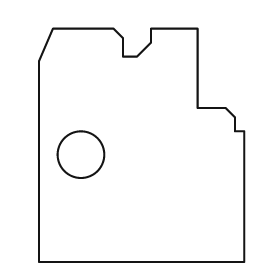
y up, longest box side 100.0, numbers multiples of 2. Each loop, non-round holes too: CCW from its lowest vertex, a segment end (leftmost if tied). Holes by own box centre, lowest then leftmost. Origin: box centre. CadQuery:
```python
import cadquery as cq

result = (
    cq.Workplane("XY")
    .moveTo(-44.0, -50.0)
    .lineTo(44.0, -50.0)
    .lineTo(44.0, 6.0)
    .lineTo(40.0, 6.0)
    .lineTo(40.0, 12.0)
    .lineTo(36.0, 16.0)
    .lineTo(24.0, 16.0)
    .lineTo(24.0, 50.0)
    .lineTo(4.0, 50.0)
    .lineTo(4.0, 44.0)
    .lineTo(-2.0, 38.0)
    .lineTo(-8.0, 38.0)
    .lineTo(-8.0, 46.0)
    .lineTo(-12.0, 50.0)
    .lineTo(-38.0, 50.0)
    .lineTo(-44.0, 36.0)
    .close()
    .moveTo(-26.0, -4.0)
    .circle(10.0)
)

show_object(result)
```